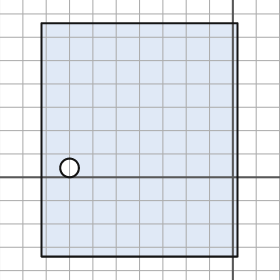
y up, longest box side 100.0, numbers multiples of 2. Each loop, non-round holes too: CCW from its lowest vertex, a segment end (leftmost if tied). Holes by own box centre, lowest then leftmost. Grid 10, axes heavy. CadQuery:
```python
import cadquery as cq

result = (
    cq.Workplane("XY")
    .moveTo(-82.0, -34.0)
    .lineTo(2.0, -34.0)
    .lineTo(2.0, 66.0)
    .lineTo(-82.0, 66.0)
    .close()
    .moveTo(-70.0, 4.0)
    .circle(4.0)
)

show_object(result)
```